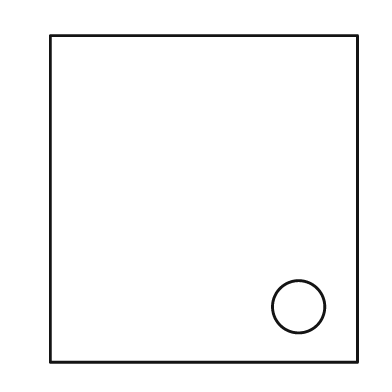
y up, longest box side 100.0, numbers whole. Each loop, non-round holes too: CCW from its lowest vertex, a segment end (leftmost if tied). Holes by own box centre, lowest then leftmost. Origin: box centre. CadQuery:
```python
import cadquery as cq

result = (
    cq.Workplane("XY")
    .moveTo(-47.0, -50.0)
    .lineTo(47.0, -50.0)
    .lineTo(47.0, 50.0)
    .lineTo(-47.0, 50.0)
    .close()
    .moveTo(29.0, -33.0)
    .circle(8.0)
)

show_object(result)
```